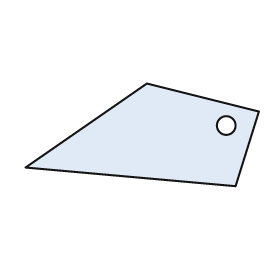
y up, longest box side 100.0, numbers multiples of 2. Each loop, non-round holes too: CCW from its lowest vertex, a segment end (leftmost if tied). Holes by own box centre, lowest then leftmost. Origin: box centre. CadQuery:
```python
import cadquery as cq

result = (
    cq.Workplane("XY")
    .moveTo(40.0, -22.0)
    .lineTo(50.0, 10.0)
    .lineTo(2.0, 22.0)
    .lineTo(-50.0, -14.0)
    .close()
    .moveTo(36.0, 4.0)
    .circle(4.0)
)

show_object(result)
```